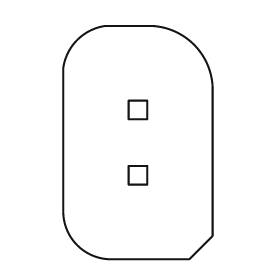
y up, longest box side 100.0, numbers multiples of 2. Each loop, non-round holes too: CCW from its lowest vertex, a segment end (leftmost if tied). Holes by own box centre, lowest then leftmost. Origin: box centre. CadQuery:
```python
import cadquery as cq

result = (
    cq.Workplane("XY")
    .moveTo(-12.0, -50.0)
    .lineTo(22.0, -50.0)
    .lineTo(32.0, -40.0)
    .lineTo(32.0, 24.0)
    .threePointArc((24.0, 42.0), (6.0, 50.0))
    .lineTo(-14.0, 50.0)
    .threePointArc((-26.0, 44.0), (-32.0, 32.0))
    .lineTo(-32.0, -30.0)
    .threePointArc((-26.0, -44.0), (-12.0, -50.0))
    .close()
    .moveTo(-4.0, -18.0)
    .lineTo(4.0, -18.0)
    .lineTo(4.0, -10.0)
    .lineTo(-4.0, -10.0)
    .close()
    .moveTo(-4.0, 10.0)
    .lineTo(4.0, 10.0)
    .lineTo(4.0, 18.0)
    .lineTo(-4.0, 18.0)
    .close()
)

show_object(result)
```